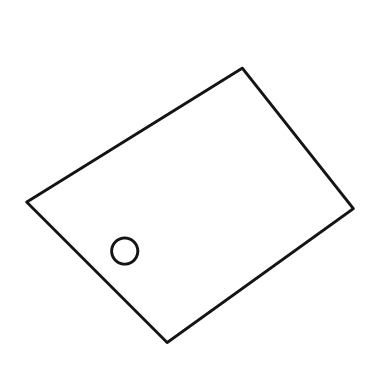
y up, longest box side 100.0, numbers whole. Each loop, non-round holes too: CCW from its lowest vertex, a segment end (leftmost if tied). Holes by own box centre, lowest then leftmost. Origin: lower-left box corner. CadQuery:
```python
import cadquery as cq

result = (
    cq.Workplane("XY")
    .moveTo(43.0, 0.0)
    .lineTo(100.0, 41.0)
    .lineTo(66.0, 84.0)
    .lineTo(0.0, 43.0)
    .close()
    .moveTo(30.0, 28.0)
    .circle(4.0)
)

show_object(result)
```